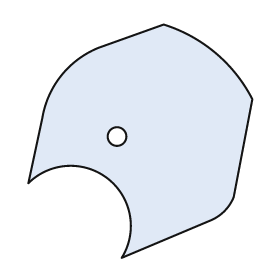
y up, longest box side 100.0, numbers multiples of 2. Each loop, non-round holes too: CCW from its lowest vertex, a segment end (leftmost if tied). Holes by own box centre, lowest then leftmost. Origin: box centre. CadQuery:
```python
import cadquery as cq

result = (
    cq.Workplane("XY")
    .moveTo(-8.0, -50.0)
    .lineTo(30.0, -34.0)
    .threePointArc((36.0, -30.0), (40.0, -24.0))
    .lineTo(48.0, 18.0)
    .threePointArc((32.0, 38.0), (10.0, 50.0))
    .lineTo(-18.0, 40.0)
    .threePointArc((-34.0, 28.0), (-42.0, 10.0))
    .lineTo(-48.0, -18.0)
    .threePointArc((-14.0, -16.0), (-8.0, -50.0))
    .close()
    .moveTo(-10.0, 2.0)
    .circle(4.0)
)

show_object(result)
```